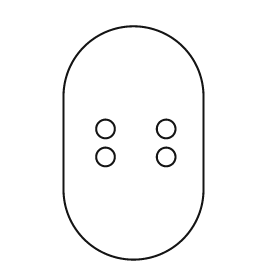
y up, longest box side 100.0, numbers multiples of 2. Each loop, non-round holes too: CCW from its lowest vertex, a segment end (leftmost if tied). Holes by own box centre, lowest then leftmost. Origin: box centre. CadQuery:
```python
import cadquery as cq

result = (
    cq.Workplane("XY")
    .moveTo(-30.0, -20.0)
    .threePointArc((0.0, -50.0), (30.0, -20.0))
    .lineTo(30.0, 20.0)
    .threePointArc((0.0, 50.0), (-30.0, 20.0))
    .close()
    .moveTo(-12.0, -6.0)
    .circle(4.0)
    .moveTo(14.0, -6.0)
    .circle(4.0)
    .moveTo(-12.0, 6.0)
    .circle(4.0)
    .moveTo(14.0, 6.0)
    .circle(4.0)
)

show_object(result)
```